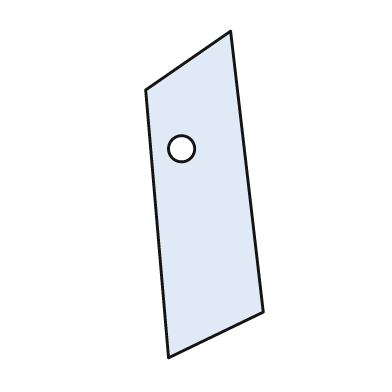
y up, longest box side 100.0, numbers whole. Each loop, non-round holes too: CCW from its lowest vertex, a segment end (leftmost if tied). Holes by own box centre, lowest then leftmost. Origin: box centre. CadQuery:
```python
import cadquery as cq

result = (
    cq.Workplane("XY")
    .moveTo(-11.0, -50.0)
    .lineTo(18.0, -36.0)
    .lineTo(8.0, 50.0)
    .lineTo(-18.0, 32.0)
    .close()
    .moveTo(-7.0, 14.0)
    .circle(4.0)
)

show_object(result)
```